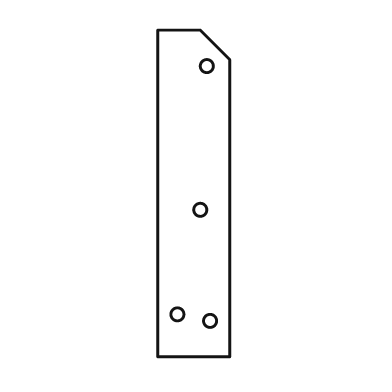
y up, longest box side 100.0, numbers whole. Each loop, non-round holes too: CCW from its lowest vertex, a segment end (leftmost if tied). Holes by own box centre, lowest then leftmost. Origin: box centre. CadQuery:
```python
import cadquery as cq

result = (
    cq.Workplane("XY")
    .moveTo(-11.0, -50.0)
    .lineTo(11.0, -50.0)
    .lineTo(11.0, 41.0)
    .lineTo(2.0, 50.0)
    .lineTo(-11.0, 50.0)
    .close()
    .moveTo(5.0, -39.0)
    .circle(2.0)
    .moveTo(-5.0, -37.0)
    .circle(2.0)
    .moveTo(2.0, -5.0)
    .circle(2.0)
    .moveTo(4.0, 39.0)
    .circle(2.0)
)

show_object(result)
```